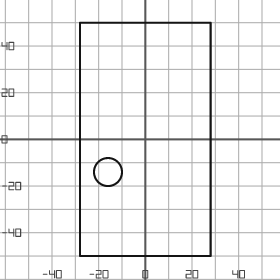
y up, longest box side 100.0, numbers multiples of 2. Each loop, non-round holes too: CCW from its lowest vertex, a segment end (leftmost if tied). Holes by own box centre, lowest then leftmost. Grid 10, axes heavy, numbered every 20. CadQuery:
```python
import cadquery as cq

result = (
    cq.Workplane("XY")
    .moveTo(-28.0, -50.0)
    .lineTo(28.0, -50.0)
    .lineTo(28.0, 50.0)
    .lineTo(-28.0, 50.0)
    .close()
    .moveTo(-16.0, -14.0)
    .circle(6.0)
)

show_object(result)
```